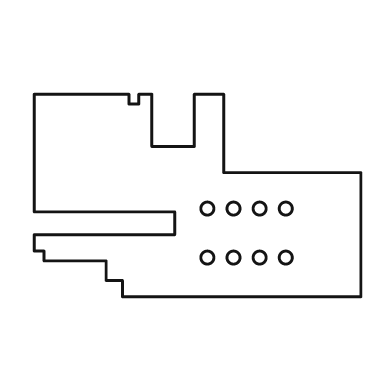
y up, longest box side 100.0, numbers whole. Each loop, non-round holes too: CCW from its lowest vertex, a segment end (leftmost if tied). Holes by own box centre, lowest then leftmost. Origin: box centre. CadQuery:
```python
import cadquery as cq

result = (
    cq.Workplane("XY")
    .moveTo(-23.0, -31.0)
    .lineTo(50.0, -31.0)
    .lineTo(50.0, 7.0)
    .lineTo(8.0, 7.0)
    .lineTo(8.0, 31.0)
    .lineTo(-1.0, 31.0)
    .lineTo(-1.0, 15.0)
    .lineTo(-14.0, 15.0)
    .lineTo(-14.0, 31.0)
    .lineTo(-18.0, 31.0)
    .lineTo(-18.0, 28.0)
    .lineTo(-21.0, 28.0)
    .lineTo(-21.0, 31.0)
    .lineTo(-50.0, 31.0)
    .lineTo(-50.0, -5.0)
    .lineTo(-7.0, -5.0)
    .lineTo(-7.0, -12.0)
    .lineTo(-50.0, -12.0)
    .lineTo(-50.0, -17.0)
    .lineTo(-47.0, -17.0)
    .lineTo(-47.0, -20.0)
    .lineTo(-28.0, -20.0)
    .lineTo(-28.0, -26.0)
    .lineTo(-23.0, -26.0)
    .close()
    .moveTo(3.0, -19.0)
    .circle(2.0)
    .moveTo(11.0, -19.0)
    .circle(2.0)
    .moveTo(19.0, -19.0)
    .circle(2.0)
    .moveTo(27.0, -19.0)
    .circle(2.0)
    .moveTo(3.0, -4.0)
    .circle(2.0)
    .moveTo(11.0, -4.0)
    .circle(2.0)
    .moveTo(19.0, -4.0)
    .circle(2.0)
    .moveTo(27.0, -4.0)
    .circle(2.0)
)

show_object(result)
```